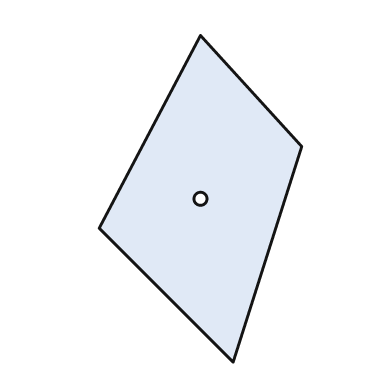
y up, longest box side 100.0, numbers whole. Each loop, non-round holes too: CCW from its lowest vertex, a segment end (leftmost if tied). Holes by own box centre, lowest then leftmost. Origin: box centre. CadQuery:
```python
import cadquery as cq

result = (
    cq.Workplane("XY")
    .moveTo(10.0, -50.0)
    .lineTo(31.0, 16.0)
    .lineTo(0.0, 50.0)
    .lineTo(-31.0, -9.0)
    .close()
    .moveTo(0.0, 0.0)
    .circle(2.0)
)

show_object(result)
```